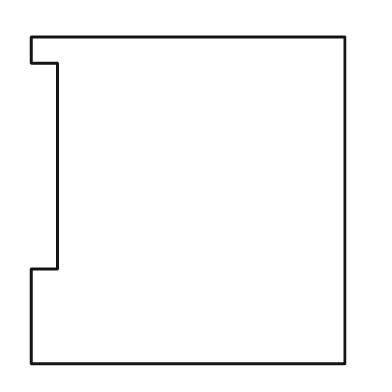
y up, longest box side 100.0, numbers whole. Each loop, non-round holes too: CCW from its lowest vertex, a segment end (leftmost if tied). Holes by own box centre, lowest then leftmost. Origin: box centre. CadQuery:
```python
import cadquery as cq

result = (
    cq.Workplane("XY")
    .moveTo(-48.0, -50.0)
    .lineTo(48.0, -50.0)
    .lineTo(48.0, 50.0)
    .lineTo(-48.0, 50.0)
    .lineTo(-48.0, 42.0)
    .lineTo(-40.0, 42.0)
    .lineTo(-40.0, -21.0)
    .lineTo(-48.0, -21.0)
    .close()
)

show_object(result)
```